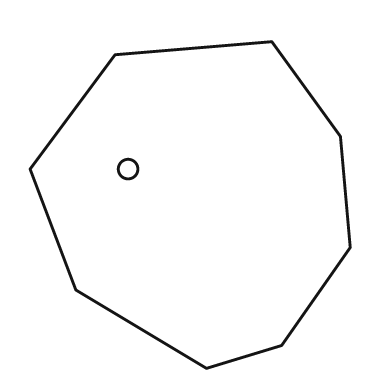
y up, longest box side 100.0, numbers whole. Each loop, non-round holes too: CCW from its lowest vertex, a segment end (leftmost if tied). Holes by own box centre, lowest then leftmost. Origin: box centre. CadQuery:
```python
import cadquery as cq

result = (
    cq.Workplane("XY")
    .moveTo(5.0, -50.0)
    .lineTo(28.0, -43.0)
    .lineTo(49.0, -13.0)
    .lineTo(46.0, 21.0)
    .lineTo(25.0, 50.0)
    .lineTo(-23.0, 46.0)
    .lineTo(-49.0, 11.0)
    .lineTo(-35.0, -26.0)
    .close()
    .moveTo(-19.0, 11.0)
    .circle(3.0)
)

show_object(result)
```